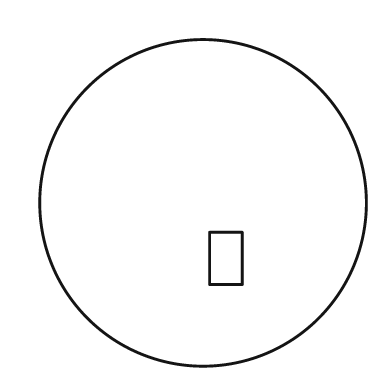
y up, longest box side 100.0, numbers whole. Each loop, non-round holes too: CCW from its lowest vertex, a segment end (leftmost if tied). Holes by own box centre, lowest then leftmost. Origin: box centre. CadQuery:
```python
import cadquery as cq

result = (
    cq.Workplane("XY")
    .moveTo(0.0, 0.0)
    .circle(50.0)
    .moveTo(2.0, -25.0)
    .lineTo(12.0, -25.0)
    .lineTo(12.0, -9.0)
    .lineTo(2.0, -9.0)
    .close()
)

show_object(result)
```